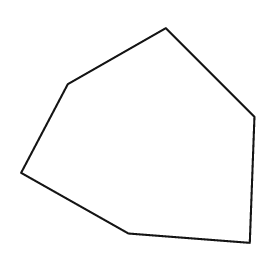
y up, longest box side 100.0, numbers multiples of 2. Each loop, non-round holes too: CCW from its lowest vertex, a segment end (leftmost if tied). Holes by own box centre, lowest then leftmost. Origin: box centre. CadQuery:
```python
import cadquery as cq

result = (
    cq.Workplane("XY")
    .moveTo(48.0, -46.0)
    .lineTo(50.0, 8.0)
    .lineTo(12.0, 46.0)
    .lineTo(-30.0, 22.0)
    .lineTo(-50.0, -16.0)
    .lineTo(-4.0, -42.0)
    .close()
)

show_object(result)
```